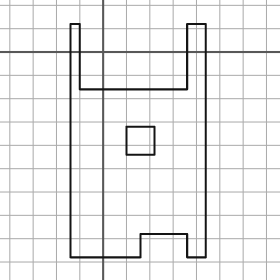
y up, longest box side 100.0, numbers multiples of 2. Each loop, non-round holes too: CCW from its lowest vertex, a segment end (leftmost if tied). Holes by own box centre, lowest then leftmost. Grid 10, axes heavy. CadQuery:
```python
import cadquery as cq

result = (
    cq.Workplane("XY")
    .moveTo(-14.0, -88.0)
    .lineTo(16.0, -88.0)
    .lineTo(16.0, -78.0)
    .lineTo(36.0, -78.0)
    .lineTo(36.0, -88.0)
    .lineTo(44.0, -88.0)
    .lineTo(44.0, 12.0)
    .lineTo(36.0, 12.0)
    .lineTo(36.0, -16.0)
    .lineTo(-10.0, -16.0)
    .lineTo(-10.0, 12.0)
    .lineTo(-14.0, 12.0)
    .close()
    .moveTo(10.0, -44.0)
    .lineTo(22.0, -44.0)
    .lineTo(22.0, -32.0)
    .lineTo(10.0, -32.0)
    .close()
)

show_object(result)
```